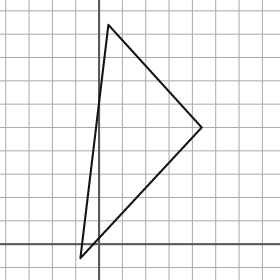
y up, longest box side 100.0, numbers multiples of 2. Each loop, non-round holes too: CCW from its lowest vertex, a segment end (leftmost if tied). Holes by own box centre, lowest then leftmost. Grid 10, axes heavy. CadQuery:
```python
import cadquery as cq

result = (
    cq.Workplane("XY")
    .moveTo(-8.0, -6.0)
    .lineTo(44.0, 50.0)
    .lineTo(4.0, 94.0)
    .close()
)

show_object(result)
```